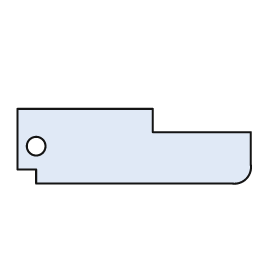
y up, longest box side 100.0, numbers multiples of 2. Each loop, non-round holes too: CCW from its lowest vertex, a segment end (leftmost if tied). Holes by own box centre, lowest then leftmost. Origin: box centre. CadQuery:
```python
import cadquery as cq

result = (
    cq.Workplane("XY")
    .moveTo(-42.0, -16.0)
    .lineTo(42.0, -16.0)
    .threePointArc((48.0, -14.0), (50.0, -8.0))
    .lineTo(50.0, 6.0)
    .lineTo(8.0, 6.0)
    .lineTo(8.0, 16.0)
    .lineTo(-50.0, 16.0)
    .lineTo(-50.0, -10.0)
    .lineTo(-42.0, -10.0)
    .close()
    .moveTo(-42.0, 0.0)
    .circle(4.0)
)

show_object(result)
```